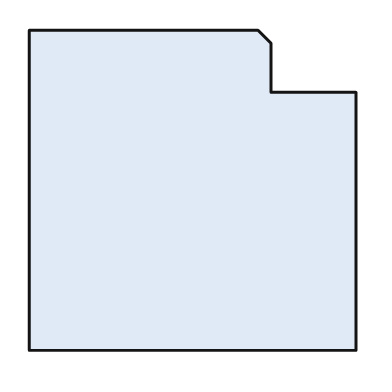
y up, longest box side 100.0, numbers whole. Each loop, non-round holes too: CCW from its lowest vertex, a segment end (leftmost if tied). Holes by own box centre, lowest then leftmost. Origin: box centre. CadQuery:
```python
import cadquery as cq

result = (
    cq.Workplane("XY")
    .moveTo(-50.0, -49.0)
    .lineTo(50.0, -49.0)
    .lineTo(50.0, 30.0)
    .lineTo(24.0, 30.0)
    .lineTo(24.0, 45.0)
    .lineTo(20.0, 49.0)
    .lineTo(-50.0, 49.0)
    .close()
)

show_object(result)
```